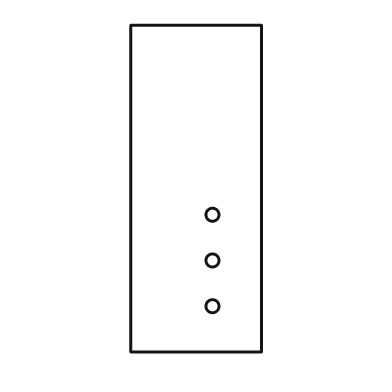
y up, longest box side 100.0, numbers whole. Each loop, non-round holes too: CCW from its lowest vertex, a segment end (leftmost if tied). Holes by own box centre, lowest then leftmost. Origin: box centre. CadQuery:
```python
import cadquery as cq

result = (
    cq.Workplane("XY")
    .moveTo(-20.0, -50.0)
    .lineTo(20.0, -50.0)
    .lineTo(20.0, 50.0)
    .lineTo(-20.0, 50.0)
    .close()
    .moveTo(5.0, -36.0)
    .circle(2.0)
    .moveTo(5.0, -22.0)
    .circle(2.0)
    .moveTo(5.0, -8.0)
    .circle(2.0)
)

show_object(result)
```